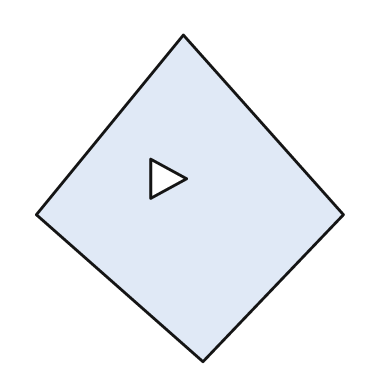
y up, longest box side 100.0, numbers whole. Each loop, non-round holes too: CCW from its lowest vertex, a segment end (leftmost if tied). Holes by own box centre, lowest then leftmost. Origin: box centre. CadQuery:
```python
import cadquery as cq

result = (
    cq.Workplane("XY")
    .moveTo(4.0, -50.0)
    .lineTo(47.0, -5.0)
    .lineTo(-2.0, 50.0)
    .lineTo(-47.0, -5.0)
    .close()
    .moveTo(-12.0, 0.0)
    .lineTo(-1.0, 6.0)
    .lineTo(-12.0, 12.0)
    .close()
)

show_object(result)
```